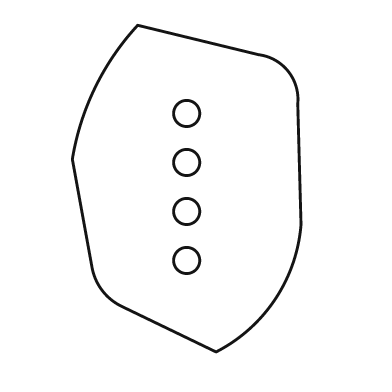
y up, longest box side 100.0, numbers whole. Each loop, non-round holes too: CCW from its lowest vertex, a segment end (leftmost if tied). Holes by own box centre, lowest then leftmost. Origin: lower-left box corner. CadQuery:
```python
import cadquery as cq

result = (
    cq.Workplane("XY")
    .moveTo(44.0, 0.0)
    .threePointArc((62.0, 16.0), (70.0, 39.0))
    .lineTo(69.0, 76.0)
    .threePointArc((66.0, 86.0), (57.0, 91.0))
    .lineTo(20.0, 100.0)
    .threePointArc((7.0, 81.0), (0.0, 59.0))
    .lineTo(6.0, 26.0)
    .threePointArc((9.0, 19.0), (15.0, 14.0))
    .close()
    .moveTo(35.0, 28.0)
    .circle(4.0)
    .moveTo(35.0, 43.0)
    .circle(4.0)
    .moveTo(35.0, 58.0)
    .circle(4.0)
    .moveTo(35.0, 73.0)
    .circle(4.0)
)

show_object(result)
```